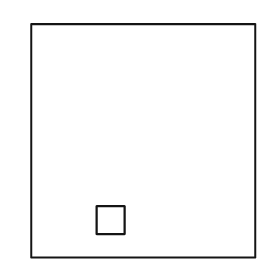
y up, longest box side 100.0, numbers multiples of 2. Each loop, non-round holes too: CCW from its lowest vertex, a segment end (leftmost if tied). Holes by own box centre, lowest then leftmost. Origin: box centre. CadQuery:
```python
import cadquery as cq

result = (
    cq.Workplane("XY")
    .moveTo(-48.0, -50.0)
    .lineTo(48.0, -50.0)
    .lineTo(48.0, 50.0)
    .lineTo(-48.0, 50.0)
    .close()
    .moveTo(-20.0, -40.0)
    .lineTo(-8.0, -40.0)
    .lineTo(-8.0, -28.0)
    .lineTo(-20.0, -28.0)
    .close()
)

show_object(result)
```